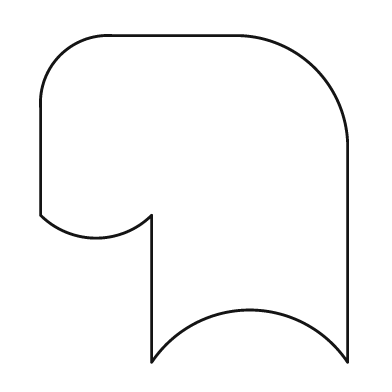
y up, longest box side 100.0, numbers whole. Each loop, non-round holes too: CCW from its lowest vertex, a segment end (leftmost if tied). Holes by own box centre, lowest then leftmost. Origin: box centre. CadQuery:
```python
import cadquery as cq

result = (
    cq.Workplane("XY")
    .moveTo(-13.0, -50.0)
    .threePointArc((17.0, -34.0), (47.0, -50.0))
    .lineTo(47.0, 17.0)
    .threePointArc((37.0, 40.0), (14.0, 50.0))
    .lineTo(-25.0, 50.0)
    .threePointArc((-41.0, 44.0), (-47.0, 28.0))
    .lineTo(-47.0, -5.0)
    .threePointArc((-30.0, -12.0), (-13.0, -5.0))
    .close()
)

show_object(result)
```